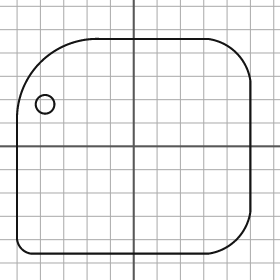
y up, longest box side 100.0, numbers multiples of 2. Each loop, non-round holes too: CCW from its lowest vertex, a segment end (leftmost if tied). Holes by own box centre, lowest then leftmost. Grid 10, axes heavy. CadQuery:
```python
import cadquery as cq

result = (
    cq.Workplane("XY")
    .moveTo(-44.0, -46.0)
    .lineTo(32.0, -46.0)
    .threePointArc((44.0, -40.0), (50.0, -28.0))
    .lineTo(50.0, 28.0)
    .threePointArc((44.0, 40.0), (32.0, 46.0))
    .lineTo(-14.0, 46.0)
    .threePointArc((-40.0, 36.0), (-50.0, 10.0))
    .lineTo(-50.0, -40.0)
    .threePointArc((-48.0, -44.0), (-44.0, -46.0))
    .close()
    .moveTo(-38.0, 18.0)
    .circle(4.0)
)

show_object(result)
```